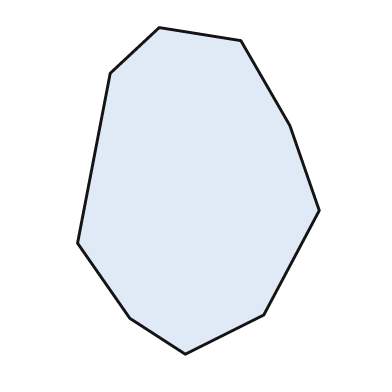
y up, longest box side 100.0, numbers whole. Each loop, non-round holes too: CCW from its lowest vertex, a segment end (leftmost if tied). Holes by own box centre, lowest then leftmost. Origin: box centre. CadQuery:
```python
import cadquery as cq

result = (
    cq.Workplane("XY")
    .moveTo(-4.0, -50.0)
    .lineTo(20.0, -38.0)
    .lineTo(37.0, -6.0)
    .lineTo(28.0, 20.0)
    .lineTo(13.0, 46.0)
    .lineTo(-12.0, 50.0)
    .lineTo(-27.0, 36.0)
    .lineTo(-37.0, -16.0)
    .lineTo(-21.0, -39.0)
    .close()
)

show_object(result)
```